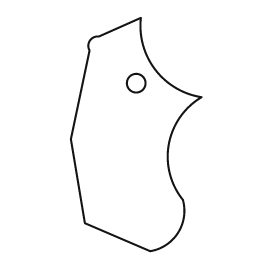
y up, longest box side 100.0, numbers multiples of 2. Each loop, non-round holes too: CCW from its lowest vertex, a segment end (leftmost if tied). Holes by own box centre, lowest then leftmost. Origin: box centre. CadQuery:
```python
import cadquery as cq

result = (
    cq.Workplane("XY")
    .moveTo(6.0, -50.0)
    .threePointArc((18.0, -42.0), (20.0, -28.0))
    .threePointArc((14.0, -4.0), (28.0, 16.0))
    .threePointArc((8.0, 28.0), (2.0, 50.0))
    .lineTo(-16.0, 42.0)
    .threePointArc((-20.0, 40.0), (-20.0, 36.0))
    .lineTo(-28.0, -2.0)
    .lineTo(-22.0, -38.0)
    .close()
    .moveTo(0.0, 22.0)
    .circle(4.0)
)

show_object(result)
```